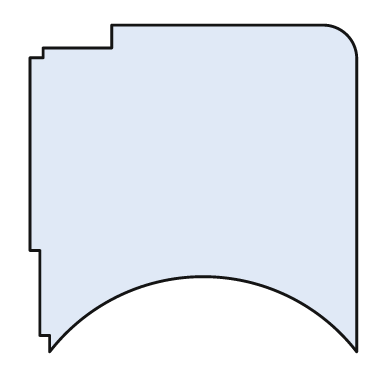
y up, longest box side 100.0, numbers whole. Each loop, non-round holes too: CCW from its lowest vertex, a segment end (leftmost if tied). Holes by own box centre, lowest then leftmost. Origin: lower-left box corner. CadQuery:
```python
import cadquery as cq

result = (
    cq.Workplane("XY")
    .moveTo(6.0, 0.0)
    .threePointArc((53.0, 23.0), (100.0, 0.0))
    .lineTo(100.0, 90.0)
    .threePointArc((97.0, 97.0), (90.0, 100.0))
    .lineTo(25.0, 100.0)
    .lineTo(25.0, 93.0)
    .lineTo(4.0, 93.0)
    .lineTo(4.0, 90.0)
    .lineTo(0.0, 90.0)
    .lineTo(0.0, 31.0)
    .lineTo(3.0, 31.0)
    .lineTo(3.0, 5.0)
    .lineTo(6.0, 5.0)
    .close()
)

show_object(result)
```